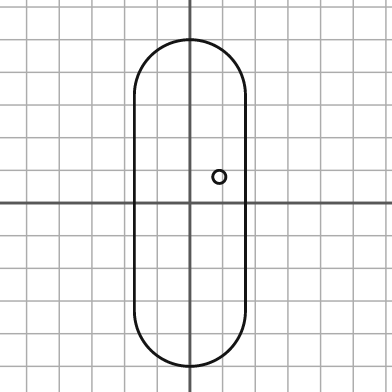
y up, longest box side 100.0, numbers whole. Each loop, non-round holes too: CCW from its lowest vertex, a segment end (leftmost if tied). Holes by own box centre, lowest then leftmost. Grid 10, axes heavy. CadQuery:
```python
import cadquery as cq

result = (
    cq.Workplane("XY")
    .moveTo(-17.0, -33.0)
    .threePointArc((0.0, -50.0), (17.0, -33.0))
    .lineTo(17.0, 33.0)
    .threePointArc((0.0, 50.0), (-17.0, 33.0))
    .close()
    .moveTo(9.0, 8.0)
    .circle(2.0)
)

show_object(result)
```